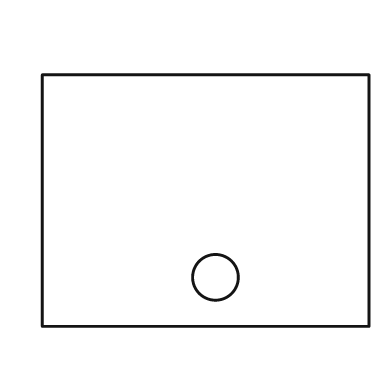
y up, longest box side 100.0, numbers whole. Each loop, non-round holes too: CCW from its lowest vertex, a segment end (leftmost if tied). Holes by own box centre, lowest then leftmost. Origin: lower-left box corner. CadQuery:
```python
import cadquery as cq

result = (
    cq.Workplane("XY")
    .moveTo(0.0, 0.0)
    .lineTo(100.0, 0.0)
    .lineTo(100.0, 77.0)
    .lineTo(0.0, 77.0)
    .close()
    .moveTo(53.0, 15.0)
    .circle(7.0)
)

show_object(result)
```